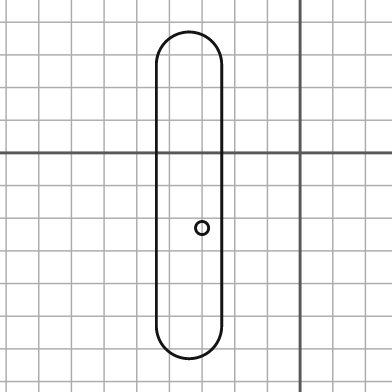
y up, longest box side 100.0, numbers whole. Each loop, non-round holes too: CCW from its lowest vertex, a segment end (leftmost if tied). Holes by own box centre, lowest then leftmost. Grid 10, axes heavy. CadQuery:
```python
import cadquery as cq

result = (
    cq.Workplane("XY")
    .moveTo(-44.0, -53.0)
    .threePointArc((-34.0, -63.0), (-24.0, -53.0))
    .lineTo(-24.0, 27.0)
    .threePointArc((-34.0, 37.0), (-44.0, 27.0))
    .close()
    .moveTo(-30.0, -23.0)
    .circle(2.0)
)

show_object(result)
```